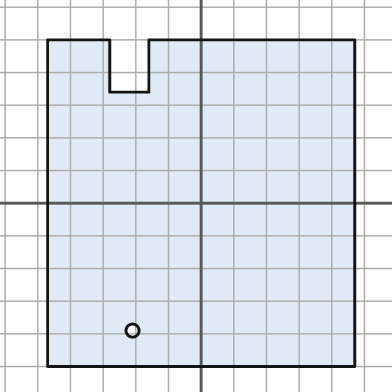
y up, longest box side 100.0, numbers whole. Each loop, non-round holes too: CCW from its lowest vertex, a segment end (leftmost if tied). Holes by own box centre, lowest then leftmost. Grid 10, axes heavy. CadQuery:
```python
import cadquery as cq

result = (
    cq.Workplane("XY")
    .moveTo(-47.0, -50.0)
    .lineTo(47.0, -50.0)
    .lineTo(47.0, 50.0)
    .lineTo(-16.0, 50.0)
    .lineTo(-16.0, 34.0)
    .lineTo(-28.0, 34.0)
    .lineTo(-28.0, 50.0)
    .lineTo(-47.0, 50.0)
    .close()
    .moveTo(-21.0, -39.0)
    .circle(2.0)
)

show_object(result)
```